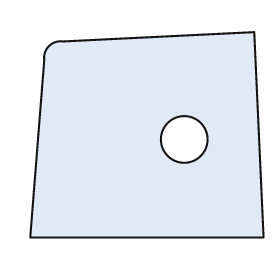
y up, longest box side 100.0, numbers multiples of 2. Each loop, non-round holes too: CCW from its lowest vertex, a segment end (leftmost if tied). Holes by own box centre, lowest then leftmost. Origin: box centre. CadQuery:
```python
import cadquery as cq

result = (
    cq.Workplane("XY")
    .moveTo(-50.0, -44.0)
    .lineTo(50.0, -44.0)
    .lineTo(46.0, 44.0)
    .lineTo(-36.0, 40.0)
    .threePointArc((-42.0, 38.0), (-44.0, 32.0))
    .close()
    .moveTo(16.0, -2.0)
    .circle(10.0)
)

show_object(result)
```